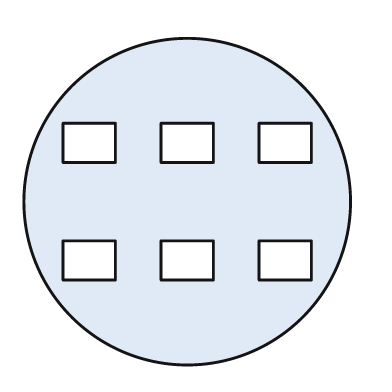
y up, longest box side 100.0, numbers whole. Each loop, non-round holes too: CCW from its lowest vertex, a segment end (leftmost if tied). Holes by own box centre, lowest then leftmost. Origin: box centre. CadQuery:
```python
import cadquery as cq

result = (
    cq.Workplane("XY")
    .moveTo(0.0, 0.0)
    .circle(50.0)
    .moveTo(-38.0, -24.0)
    .lineTo(-22.0, -24.0)
    .lineTo(-22.0, -12.0)
    .lineTo(-38.0, -12.0)
    .close()
    .moveTo(-8.0, -24.0)
    .lineTo(8.0, -24.0)
    .lineTo(8.0, -12.0)
    .lineTo(-8.0, -12.0)
    .close()
    .moveTo(22.0, -24.0)
    .lineTo(38.0, -24.0)
    .lineTo(38.0, -12.0)
    .lineTo(22.0, -12.0)
    .close()
    .moveTo(-38.0, 12.0)
    .lineTo(-22.0, 12.0)
    .lineTo(-22.0, 24.0)
    .lineTo(-38.0, 24.0)
    .close()
    .moveTo(-8.0, 12.0)
    .lineTo(8.0, 12.0)
    .lineTo(8.0, 24.0)
    .lineTo(-8.0, 24.0)
    .close()
    .moveTo(22.0, 12.0)
    .lineTo(38.0, 12.0)
    .lineTo(38.0, 24.0)
    .lineTo(22.0, 24.0)
    .close()
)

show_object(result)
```